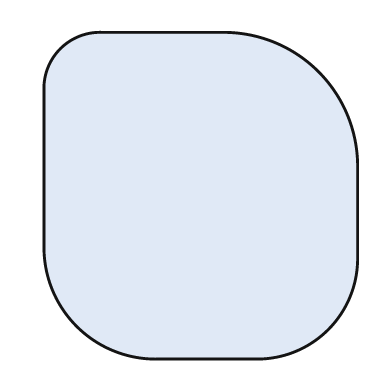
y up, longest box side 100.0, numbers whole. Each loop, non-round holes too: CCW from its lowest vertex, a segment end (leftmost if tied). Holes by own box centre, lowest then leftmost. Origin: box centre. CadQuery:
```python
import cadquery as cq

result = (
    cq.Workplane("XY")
    .moveTo(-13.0, -50.0)
    .lineTo(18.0, -50.0)
    .threePointArc((39.0, -41.0), (48.0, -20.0))
    .lineTo(48.0, 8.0)
    .threePointArc((36.0, 38.0), (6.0, 50.0))
    .lineTo(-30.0, 50.0)
    .threePointArc((-43.0, 45.0), (-48.0, 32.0))
    .lineTo(-48.0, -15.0)
    .threePointArc((-38.0, -40.0), (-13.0, -50.0))
    .close()
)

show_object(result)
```